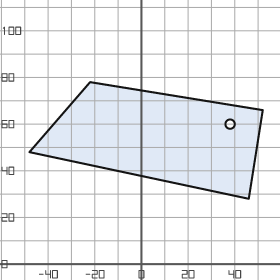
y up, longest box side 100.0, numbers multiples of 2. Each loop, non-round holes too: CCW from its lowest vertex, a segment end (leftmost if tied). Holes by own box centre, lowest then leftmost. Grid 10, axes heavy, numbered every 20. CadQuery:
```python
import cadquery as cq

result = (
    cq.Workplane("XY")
    .moveTo(46.0, 28.0)
    .lineTo(52.0, 66.0)
    .lineTo(-22.0, 78.0)
    .lineTo(-48.0, 48.0)
    .close()
    .moveTo(38.0, 60.0)
    .circle(2.0)
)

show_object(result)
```